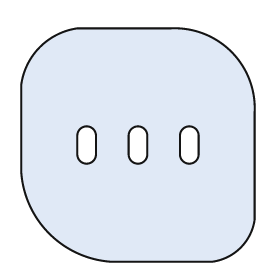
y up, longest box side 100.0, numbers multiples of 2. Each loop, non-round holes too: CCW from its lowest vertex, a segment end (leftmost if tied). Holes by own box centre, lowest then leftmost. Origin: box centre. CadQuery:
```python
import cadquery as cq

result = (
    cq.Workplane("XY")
    .moveTo(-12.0, -50.0)
    .lineTo(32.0, -50.0)
    .threePointArc((44.0, -44.0), (50.0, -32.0))
    .lineTo(50.0, 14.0)
    .threePointArc((40.0, 40.0), (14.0, 50.0))
    .lineTo(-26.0, 50.0)
    .threePointArc((-42.0, 42.0), (-50.0, 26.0))
    .lineTo(-50.0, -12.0)
    .threePointArc((-38.0, -38.0), (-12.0, -50.0))
    .close()
    .moveTo(-26.0, -4.0)
    .threePointArc((-22.0, -8.0), (-18.0, -4.0))
    .lineTo(-18.0, 4.0)
    .threePointArc((-22.0, 8.0), (-26.0, 4.0))
    .close()
    .moveTo(-4.0, -4.0)
    .threePointArc((0.0, -8.0), (4.0, -4.0))
    .lineTo(4.0, 4.0)
    .threePointArc((0.0, 8.0), (-4.0, 4.0))
    .close()
    .moveTo(18.0, -4.0)
    .threePointArc((22.0, -8.0), (26.0, -4.0))
    .lineTo(26.0, 4.0)
    .threePointArc((22.0, 8.0), (18.0, 4.0))
    .close()
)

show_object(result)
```